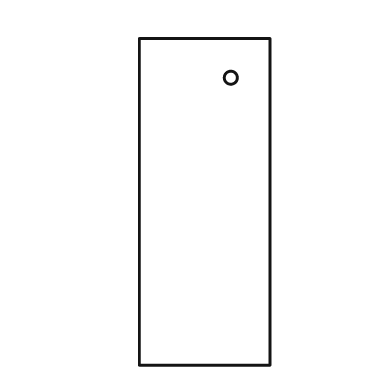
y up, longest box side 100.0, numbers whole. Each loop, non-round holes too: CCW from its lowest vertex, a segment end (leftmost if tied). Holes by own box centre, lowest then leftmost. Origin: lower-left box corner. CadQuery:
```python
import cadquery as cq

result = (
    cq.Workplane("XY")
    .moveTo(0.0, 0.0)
    .lineTo(40.0, 0.0)
    .lineTo(40.0, 100.0)
    .lineTo(0.0, 100.0)
    .close()
    .moveTo(28.0, 88.0)
    .circle(2.0)
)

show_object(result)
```